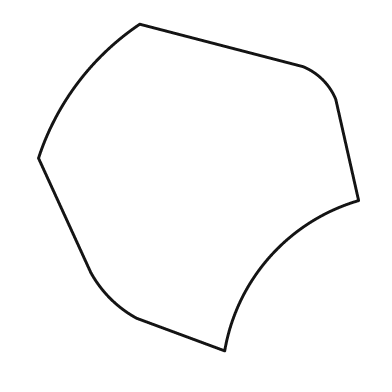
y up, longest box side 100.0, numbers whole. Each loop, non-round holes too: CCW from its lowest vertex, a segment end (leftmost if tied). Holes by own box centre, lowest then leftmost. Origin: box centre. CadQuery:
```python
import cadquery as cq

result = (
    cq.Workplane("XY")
    .moveTo(8.0, -50.0)
    .threePointArc((22.0, -21.0), (49.0, -4.0))
    .lineTo(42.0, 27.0)
    .threePointArc((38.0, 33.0), (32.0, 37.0))
    .lineTo(-18.0, 50.0)
    .threePointArc((-37.0, 32.0), (-49.0, 9.0))
    .lineTo(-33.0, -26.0)
    .threePointArc((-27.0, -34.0), (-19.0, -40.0))
    .close()
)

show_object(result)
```